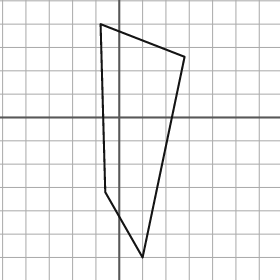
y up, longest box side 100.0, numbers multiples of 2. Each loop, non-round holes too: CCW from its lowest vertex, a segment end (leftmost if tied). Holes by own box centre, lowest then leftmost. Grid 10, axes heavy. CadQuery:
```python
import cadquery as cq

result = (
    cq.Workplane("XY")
    .moveTo(10.0, -60.0)
    .lineTo(28.0, 26.0)
    .lineTo(-8.0, 40.0)
    .lineTo(-6.0, -32.0)
    .close()
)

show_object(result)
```